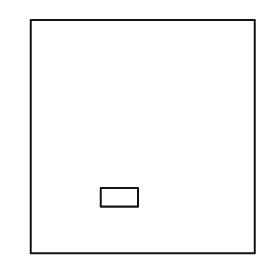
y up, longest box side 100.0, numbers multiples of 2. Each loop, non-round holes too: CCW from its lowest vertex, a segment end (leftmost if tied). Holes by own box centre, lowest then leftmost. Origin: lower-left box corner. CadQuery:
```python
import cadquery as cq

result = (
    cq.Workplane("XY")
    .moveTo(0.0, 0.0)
    .lineTo(96.0, 0.0)
    .lineTo(96.0, 100.0)
    .lineTo(0.0, 100.0)
    .close()
    .moveTo(30.0, 20.0)
    .lineTo(46.0, 20.0)
    .lineTo(46.0, 28.0)
    .lineTo(30.0, 28.0)
    .close()
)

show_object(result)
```